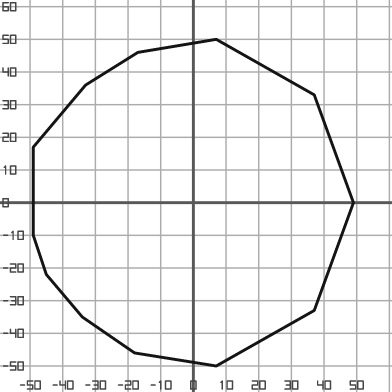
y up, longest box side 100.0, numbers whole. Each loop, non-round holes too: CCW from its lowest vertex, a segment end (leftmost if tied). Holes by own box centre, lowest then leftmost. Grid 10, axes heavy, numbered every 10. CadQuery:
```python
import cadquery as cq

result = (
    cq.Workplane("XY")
    .moveTo(7.0, -50.0)
    .lineTo(37.0, -33.0)
    .lineTo(49.0, 0.0)
    .lineTo(37.0, 33.0)
    .lineTo(7.0, 50.0)
    .lineTo(-17.0, 46.0)
    .lineTo(-33.0, 36.0)
    .lineTo(-49.0, 17.0)
    .lineTo(-49.0, -10.0)
    .lineTo(-45.0, -22.0)
    .lineTo(-34.0, -35.0)
    .lineTo(-18.0, -46.0)
    .close()
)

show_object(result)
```